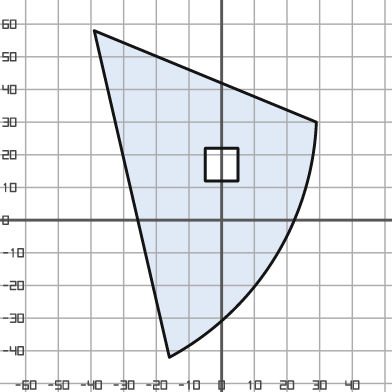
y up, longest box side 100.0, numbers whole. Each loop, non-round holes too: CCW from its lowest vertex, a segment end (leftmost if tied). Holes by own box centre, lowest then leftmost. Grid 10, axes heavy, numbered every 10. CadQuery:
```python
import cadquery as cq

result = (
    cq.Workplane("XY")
    .moveTo(-16.0, -42.0)
    .threePointArc((16.0, -12.0), (29.0, 30.0))
    .lineTo(-39.0, 58.0)
    .close()
    .moveTo(-5.0, 12.0)
    .lineTo(5.0, 12.0)
    .lineTo(5.0, 22.0)
    .lineTo(-5.0, 22.0)
    .close()
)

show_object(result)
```